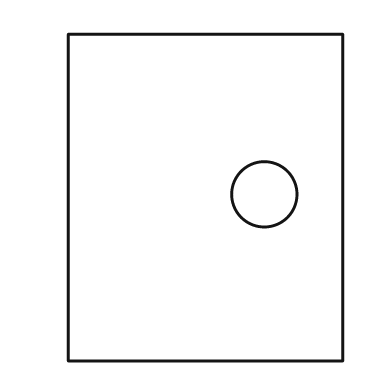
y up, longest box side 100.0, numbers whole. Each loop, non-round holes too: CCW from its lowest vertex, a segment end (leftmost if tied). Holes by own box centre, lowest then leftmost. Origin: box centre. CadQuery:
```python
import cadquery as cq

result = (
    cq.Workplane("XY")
    .moveTo(-42.0, -50.0)
    .lineTo(42.0, -50.0)
    .lineTo(42.0, 50.0)
    .lineTo(-42.0, 50.0)
    .close()
    .moveTo(18.0, 1.0)
    .circle(10.0)
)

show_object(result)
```